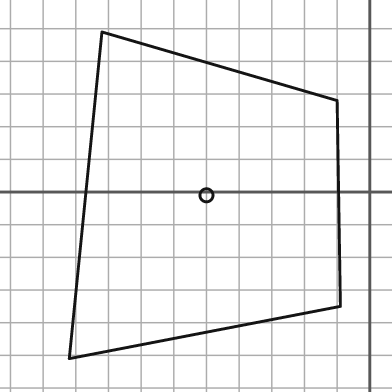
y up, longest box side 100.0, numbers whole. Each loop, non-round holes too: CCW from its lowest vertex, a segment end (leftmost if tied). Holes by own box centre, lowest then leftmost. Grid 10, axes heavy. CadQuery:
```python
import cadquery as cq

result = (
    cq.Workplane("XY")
    .moveTo(-92.0, -51.0)
    .lineTo(-9.0, -35.0)
    .lineTo(-10.0, 28.0)
    .lineTo(-82.0, 49.0)
    .close()
    .moveTo(-50.0, -1.0)
    .circle(2.0)
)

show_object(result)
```